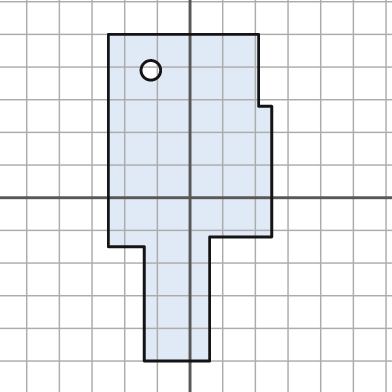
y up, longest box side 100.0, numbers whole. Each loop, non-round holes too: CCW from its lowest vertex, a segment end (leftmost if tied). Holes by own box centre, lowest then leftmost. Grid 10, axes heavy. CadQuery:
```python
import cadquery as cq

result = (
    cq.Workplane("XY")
    .moveTo(-14.0, -50.0)
    .lineTo(6.0, -50.0)
    .lineTo(6.0, -12.0)
    .lineTo(25.0, -12.0)
    .lineTo(25.0, 28.0)
    .lineTo(21.0, 28.0)
    .lineTo(21.0, 50.0)
    .lineTo(-25.0, 50.0)
    .lineTo(-25.0, -15.0)
    .lineTo(-14.0, -15.0)
    .close()
    .moveTo(-12.0, 39.0)
    .circle(3.0)
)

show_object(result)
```